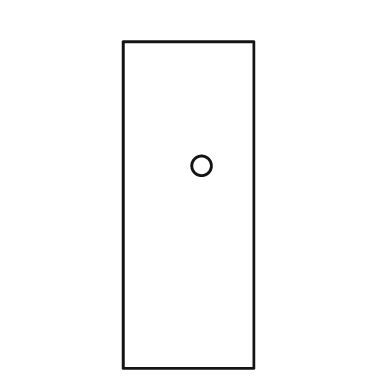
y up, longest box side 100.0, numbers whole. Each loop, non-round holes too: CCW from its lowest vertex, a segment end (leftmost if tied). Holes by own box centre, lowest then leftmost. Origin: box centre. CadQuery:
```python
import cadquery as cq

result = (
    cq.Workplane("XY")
    .moveTo(-20.0, -50.0)
    .lineTo(20.0, -50.0)
    .lineTo(20.0, 50.0)
    .lineTo(-20.0, 50.0)
    .close()
    .moveTo(4.0, 12.0)
    .circle(3.0)
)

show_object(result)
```